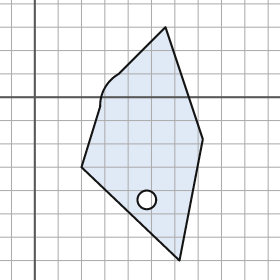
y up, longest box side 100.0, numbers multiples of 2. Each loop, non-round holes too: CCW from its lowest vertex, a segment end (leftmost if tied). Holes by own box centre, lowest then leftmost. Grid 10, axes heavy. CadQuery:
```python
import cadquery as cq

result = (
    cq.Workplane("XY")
    .moveTo(62.0, -70.0)
    .lineTo(72.0, -18.0)
    .lineTo(56.0, 30.0)
    .lineTo(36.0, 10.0)
    .threePointArc((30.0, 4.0), (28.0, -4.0))
    .lineTo(20.0, -30.0)
    .close()
    .moveTo(48.0, -44.0)
    .circle(4.0)
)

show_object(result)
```